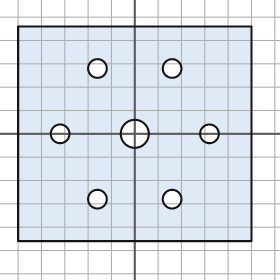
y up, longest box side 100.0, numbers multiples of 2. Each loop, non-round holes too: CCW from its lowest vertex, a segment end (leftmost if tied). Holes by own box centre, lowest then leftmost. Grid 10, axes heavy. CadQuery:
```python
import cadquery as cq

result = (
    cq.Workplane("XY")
    .moveTo(-50.0, -46.0)
    .lineTo(50.0, -46.0)
    .lineTo(50.0, 46.0)
    .lineTo(-50.0, 46.0)
    .close()
    .moveTo(-16.0, -28.0)
    .circle(4.0)
    .moveTo(16.0, -28.0)
    .circle(4.0)
    .moveTo(-32.0, 0.0)
    .circle(4.0)
    .moveTo(0.0, 0.0)
    .circle(6.0)
    .moveTo(32.0, 0.0)
    .circle(4.0)
    .moveTo(-16.0, 28.0)
    .circle(4.0)
    .moveTo(16.0, 28.0)
    .circle(4.0)
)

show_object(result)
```